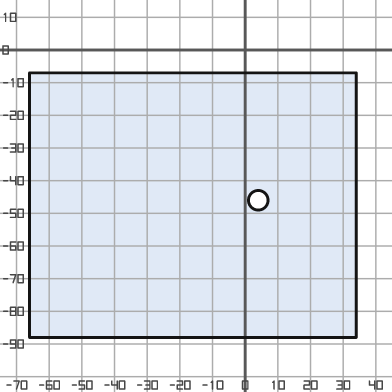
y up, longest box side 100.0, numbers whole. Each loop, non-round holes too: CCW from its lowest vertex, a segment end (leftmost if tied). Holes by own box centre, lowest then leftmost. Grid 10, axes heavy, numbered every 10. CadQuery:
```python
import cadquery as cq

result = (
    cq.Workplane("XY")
    .moveTo(-66.0, -88.0)
    .lineTo(34.0, -88.0)
    .lineTo(34.0, -7.0)
    .lineTo(-66.0, -7.0)
    .close()
    .moveTo(4.0, -46.0)
    .circle(3.0)
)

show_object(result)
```